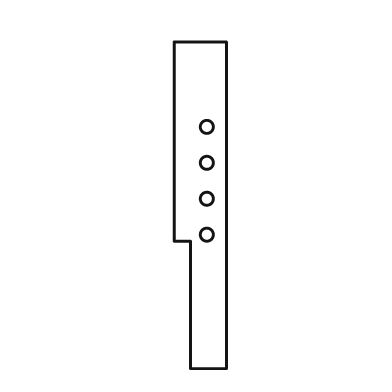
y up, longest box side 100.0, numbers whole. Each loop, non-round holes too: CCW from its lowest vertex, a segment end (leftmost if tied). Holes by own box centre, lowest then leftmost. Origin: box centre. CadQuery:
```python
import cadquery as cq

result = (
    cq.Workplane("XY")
    .moveTo(-3.0, -50.0)
    .lineTo(8.0, -50.0)
    .lineTo(8.0, 50.0)
    .lineTo(-8.0, 50.0)
    .lineTo(-8.0, -11.0)
    .lineTo(-3.0, -11.0)
    .close()
    .moveTo(2.0, -9.0)
    .circle(2.0)
    .moveTo(2.0, 2.0)
    .circle(2.0)
    .moveTo(2.0, 13.0)
    .circle(2.0)
    .moveTo(2.0, 24.0)
    .circle(2.0)
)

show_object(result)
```